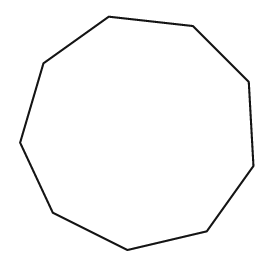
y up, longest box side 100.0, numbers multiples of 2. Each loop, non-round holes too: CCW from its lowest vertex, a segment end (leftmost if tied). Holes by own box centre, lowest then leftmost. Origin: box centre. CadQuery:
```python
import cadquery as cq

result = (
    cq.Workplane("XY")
    .moveTo(-4.0, -50.0)
    .lineTo(30.0, -42.0)
    .lineTo(50.0, -14.0)
    .lineTo(48.0, 22.0)
    .lineTo(24.0, 46.0)
    .lineTo(-12.0, 50.0)
    .lineTo(-40.0, 30.0)
    .lineTo(-50.0, -4.0)
    .lineTo(-36.0, -34.0)
    .close()
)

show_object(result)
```